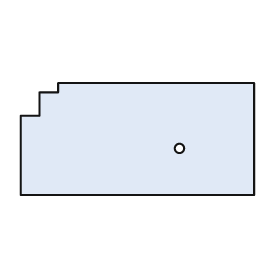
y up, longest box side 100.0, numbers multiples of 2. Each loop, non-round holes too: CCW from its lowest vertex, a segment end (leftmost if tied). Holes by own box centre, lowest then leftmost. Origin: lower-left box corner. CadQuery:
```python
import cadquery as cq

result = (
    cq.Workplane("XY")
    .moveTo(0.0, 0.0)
    .lineTo(100.0, 0.0)
    .lineTo(100.0, 48.0)
    .lineTo(16.0, 48.0)
    .lineTo(16.0, 44.0)
    .lineTo(8.0, 44.0)
    .lineTo(8.0, 34.0)
    .lineTo(0.0, 34.0)
    .close()
    .moveTo(68.0, 20.0)
    .circle(2.0)
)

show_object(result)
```